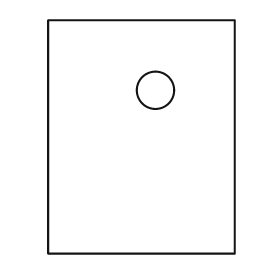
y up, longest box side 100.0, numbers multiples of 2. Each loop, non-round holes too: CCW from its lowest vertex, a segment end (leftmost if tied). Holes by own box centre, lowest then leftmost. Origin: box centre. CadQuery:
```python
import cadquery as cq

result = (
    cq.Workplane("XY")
    .moveTo(-40.0, -50.0)
    .lineTo(40.0, -50.0)
    .lineTo(40.0, 50.0)
    .lineTo(-40.0, 50.0)
    .close()
    .moveTo(6.0, 20.0)
    .circle(8.0)
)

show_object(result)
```